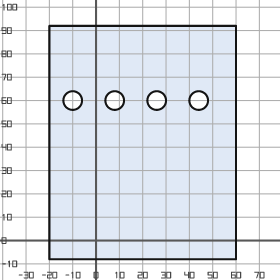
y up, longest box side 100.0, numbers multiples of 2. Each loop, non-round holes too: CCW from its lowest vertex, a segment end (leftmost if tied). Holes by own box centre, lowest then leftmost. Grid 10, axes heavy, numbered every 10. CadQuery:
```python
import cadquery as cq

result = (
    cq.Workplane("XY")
    .moveTo(-20.0, -8.0)
    .lineTo(60.0, -8.0)
    .lineTo(60.0, 92.0)
    .lineTo(-20.0, 92.0)
    .close()
    .moveTo(-10.0, 60.0)
    .circle(4.0)
    .moveTo(8.0, 60.0)
    .circle(4.0)
    .moveTo(26.0, 60.0)
    .circle(4.0)
    .moveTo(44.0, 60.0)
    .circle(4.0)
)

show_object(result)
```